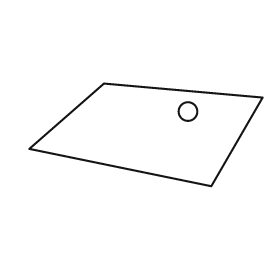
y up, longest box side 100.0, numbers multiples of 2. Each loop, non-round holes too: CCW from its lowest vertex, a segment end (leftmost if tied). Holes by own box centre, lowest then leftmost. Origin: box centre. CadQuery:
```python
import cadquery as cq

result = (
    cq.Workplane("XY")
    .moveTo(28.0, -22.0)
    .lineTo(50.0, 16.0)
    .lineTo(-18.0, 22.0)
    .lineTo(-50.0, -6.0)
    .close()
    .moveTo(18.0, 10.0)
    .circle(4.0)
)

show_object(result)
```